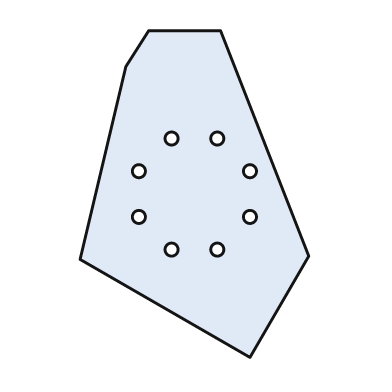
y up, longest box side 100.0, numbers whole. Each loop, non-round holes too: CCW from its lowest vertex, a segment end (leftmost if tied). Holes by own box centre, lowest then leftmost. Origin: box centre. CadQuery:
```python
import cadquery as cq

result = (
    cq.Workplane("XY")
    .moveTo(17.0, -50.0)
    .lineTo(35.0, -19.0)
    .lineTo(8.0, 50.0)
    .lineTo(-14.0, 50.0)
    .lineTo(-21.0, 39.0)
    .lineTo(-35.0, -20.0)
    .close()
    .moveTo(-7.0, -17.0)
    .circle(2.0)
    .moveTo(7.0, -17.0)
    .circle(2.0)
    .moveTo(-17.0, -7.0)
    .circle(2.0)
    .moveTo(17.0, -7.0)
    .circle(2.0)
    .moveTo(-17.0, 7.0)
    .circle(2.0)
    .moveTo(17.0, 7.0)
    .circle(2.0)
    .moveTo(-7.0, 17.0)
    .circle(2.0)
    .moveTo(7.0, 17.0)
    .circle(2.0)
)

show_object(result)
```